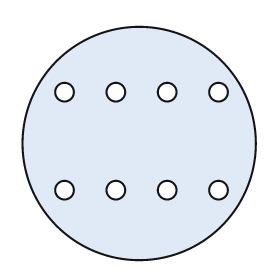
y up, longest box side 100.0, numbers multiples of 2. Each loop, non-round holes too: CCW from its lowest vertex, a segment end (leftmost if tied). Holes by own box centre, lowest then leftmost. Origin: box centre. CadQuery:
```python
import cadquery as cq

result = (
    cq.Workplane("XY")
    .moveTo(0.0, 0.0)
    .circle(50.0)
    .moveTo(-32.0, -20.0)
    .circle(4.0)
    .moveTo(-10.0, -20.0)
    .circle(4.0)
    .moveTo(12.0, -20.0)
    .circle(4.0)
    .moveTo(34.0, -20.0)
    .circle(4.0)
    .moveTo(-32.0, 22.0)
    .circle(4.0)
    .moveTo(-10.0, 22.0)
    .circle(4.0)
    .moveTo(12.0, 22.0)
    .circle(4.0)
    .moveTo(34.0, 22.0)
    .circle(4.0)
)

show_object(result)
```